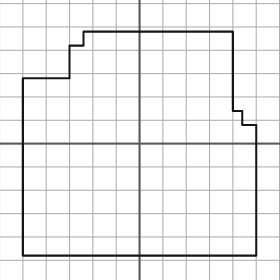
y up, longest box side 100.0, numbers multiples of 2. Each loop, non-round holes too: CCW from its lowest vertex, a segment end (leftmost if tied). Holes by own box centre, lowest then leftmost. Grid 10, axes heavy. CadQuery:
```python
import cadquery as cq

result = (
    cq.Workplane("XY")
    .moveTo(-50.0, -48.0)
    .lineTo(50.0, -48.0)
    .lineTo(50.0, 8.0)
    .lineTo(44.0, 8.0)
    .lineTo(44.0, 14.0)
    .lineTo(40.0, 14.0)
    .lineTo(40.0, 48.0)
    .lineTo(-24.0, 48.0)
    .lineTo(-24.0, 42.0)
    .lineTo(-30.0, 42.0)
    .lineTo(-30.0, 28.0)
    .lineTo(-50.0, 28.0)
    .close()
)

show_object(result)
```